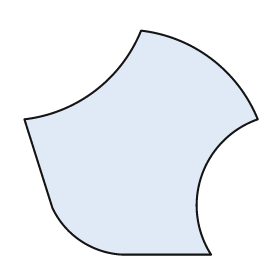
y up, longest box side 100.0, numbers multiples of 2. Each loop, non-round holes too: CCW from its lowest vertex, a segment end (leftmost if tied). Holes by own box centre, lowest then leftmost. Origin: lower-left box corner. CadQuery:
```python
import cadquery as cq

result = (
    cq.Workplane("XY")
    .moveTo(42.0, 0.0)
    .lineTo(80.0, 0.0)
    .threePointArc((76.0, 34.0), (100.0, 58.0))
    .threePointArc((80.0, 84.0), (50.0, 96.0))
    .threePointArc((30.0, 70.0), (0.0, 58.0))
    .lineTo(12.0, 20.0)
    .threePointArc((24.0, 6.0), (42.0, 0.0))
    .close()
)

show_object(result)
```